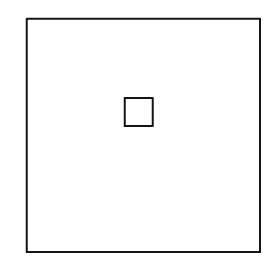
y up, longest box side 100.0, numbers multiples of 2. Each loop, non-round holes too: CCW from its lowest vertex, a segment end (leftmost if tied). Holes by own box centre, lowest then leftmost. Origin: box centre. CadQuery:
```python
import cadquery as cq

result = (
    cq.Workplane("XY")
    .moveTo(-50.0, -50.0)
    .lineTo(50.0, -50.0)
    .lineTo(50.0, 50.0)
    .lineTo(-50.0, 50.0)
    .close()
    .moveTo(-8.0, 4.0)
    .lineTo(4.0, 4.0)
    .lineTo(4.0, 16.0)
    .lineTo(-8.0, 16.0)
    .close()
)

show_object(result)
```